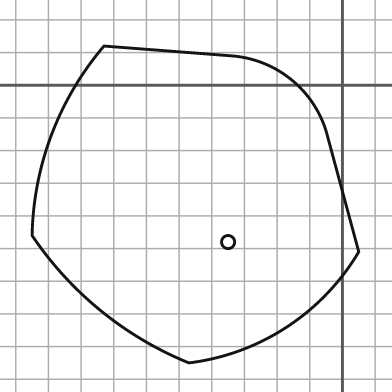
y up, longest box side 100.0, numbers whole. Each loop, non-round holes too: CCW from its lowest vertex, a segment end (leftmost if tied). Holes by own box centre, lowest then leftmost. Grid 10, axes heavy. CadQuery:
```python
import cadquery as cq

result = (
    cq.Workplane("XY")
    .moveTo(-47.0, -85.0)
    .threePointArc((-17.0, -74.0), (5.0, -51.0))
    .lineTo(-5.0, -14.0)
    .threePointArc((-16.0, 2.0), (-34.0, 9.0))
    .lineTo(-73.0, 12.0)
    .threePointArc((-89.0, -15.0), (-95.0, -46.0))
    .threePointArc((-74.0, -69.0), (-47.0, -85.0))
    .close()
    .moveTo(-35.0, -48.0)
    .circle(2.0)
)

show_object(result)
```